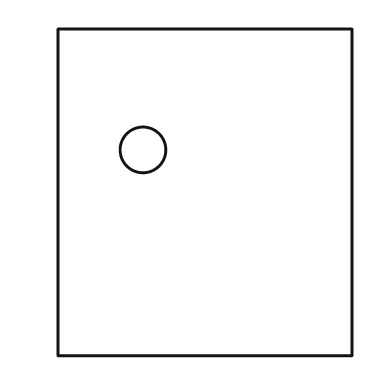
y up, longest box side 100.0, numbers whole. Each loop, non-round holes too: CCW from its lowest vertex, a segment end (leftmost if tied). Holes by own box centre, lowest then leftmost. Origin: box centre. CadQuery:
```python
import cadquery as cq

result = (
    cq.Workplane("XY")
    .moveTo(-45.0, -50.0)
    .lineTo(45.0, -50.0)
    .lineTo(45.0, 50.0)
    .lineTo(-45.0, 50.0)
    .close()
    .moveTo(-19.0, 13.0)
    .circle(7.0)
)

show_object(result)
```